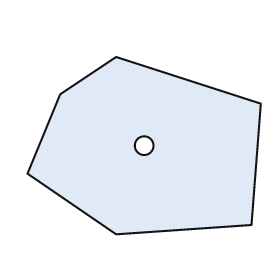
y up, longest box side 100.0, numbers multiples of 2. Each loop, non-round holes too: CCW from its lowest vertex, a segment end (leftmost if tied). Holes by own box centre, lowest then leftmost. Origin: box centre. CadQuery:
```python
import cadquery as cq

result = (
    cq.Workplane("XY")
    .moveTo(-12.0, -38.0)
    .lineTo(46.0, -34.0)
    .lineTo(50.0, 18.0)
    .lineTo(-12.0, 38.0)
    .lineTo(-36.0, 22.0)
    .lineTo(-50.0, -12.0)
    .close()
    .moveTo(0.0, 0.0)
    .circle(4.0)
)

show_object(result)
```